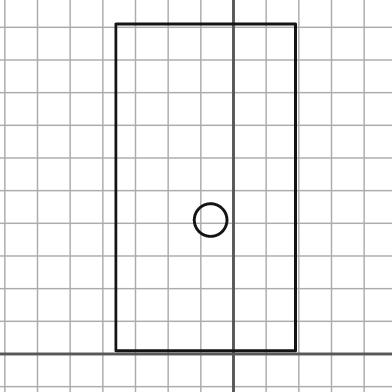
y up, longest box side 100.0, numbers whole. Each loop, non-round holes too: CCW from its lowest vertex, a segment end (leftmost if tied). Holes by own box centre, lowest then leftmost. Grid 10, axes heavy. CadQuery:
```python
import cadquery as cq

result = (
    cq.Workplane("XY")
    .moveTo(-36.0, 1.0)
    .lineTo(19.0, 1.0)
    .lineTo(19.0, 101.0)
    .lineTo(-36.0, 101.0)
    .close()
    .moveTo(-7.0, 41.0)
    .circle(5.0)
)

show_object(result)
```